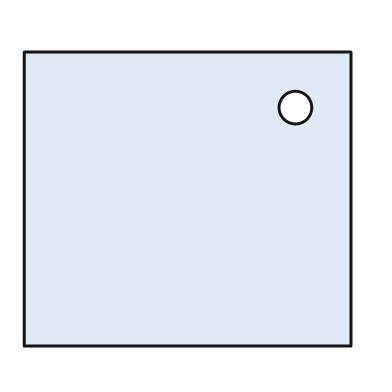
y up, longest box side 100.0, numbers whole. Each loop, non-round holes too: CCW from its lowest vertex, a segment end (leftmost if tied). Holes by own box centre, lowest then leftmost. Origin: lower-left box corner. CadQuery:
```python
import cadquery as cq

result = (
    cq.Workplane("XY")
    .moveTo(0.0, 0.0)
    .lineTo(100.0, 0.0)
    .lineTo(100.0, 90.0)
    .lineTo(0.0, 90.0)
    .close()
    .moveTo(83.0, 73.0)
    .circle(5.0)
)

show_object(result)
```